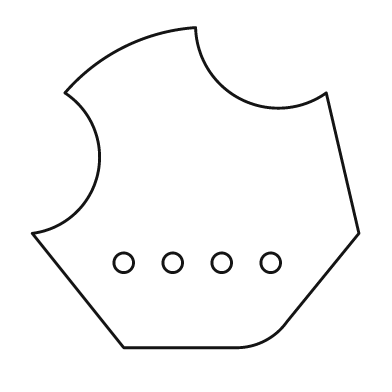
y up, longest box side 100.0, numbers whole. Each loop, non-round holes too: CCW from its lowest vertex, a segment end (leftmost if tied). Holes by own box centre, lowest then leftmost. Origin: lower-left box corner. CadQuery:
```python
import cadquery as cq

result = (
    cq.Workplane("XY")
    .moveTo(28.0, 0.0)
    .lineTo(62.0, 0.0)
    .threePointArc((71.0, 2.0), (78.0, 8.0))
    .lineTo(100.0, 35.0)
    .lineTo(90.0, 78.0)
    .threePointArc((64.0, 76.0), (50.0, 98.0))
    .threePointArc((28.0, 92.0), (10.0, 78.0))
    .threePointArc((20.0, 53.0), (0.0, 35.0))
    .close()
    .moveTo(28.0, 26.0)
    .circle(3.0)
    .moveTo(43.0, 26.0)
    .circle(3.0)
    .moveTo(58.0, 26.0)
    .circle(3.0)
    .moveTo(73.0, 26.0)
    .circle(3.0)
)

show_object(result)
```